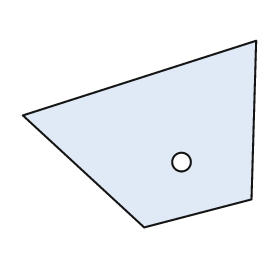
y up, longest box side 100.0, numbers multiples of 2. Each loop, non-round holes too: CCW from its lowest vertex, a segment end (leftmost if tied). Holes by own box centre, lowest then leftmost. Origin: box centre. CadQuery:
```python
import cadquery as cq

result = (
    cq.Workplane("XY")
    .moveTo(2.0, -40.0)
    .lineTo(48.0, -28.0)
    .lineTo(50.0, 40.0)
    .lineTo(-50.0, 8.0)
    .close()
    .moveTo(18.0, -12.0)
    .circle(4.0)
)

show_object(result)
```